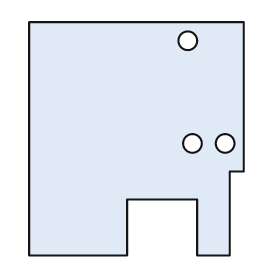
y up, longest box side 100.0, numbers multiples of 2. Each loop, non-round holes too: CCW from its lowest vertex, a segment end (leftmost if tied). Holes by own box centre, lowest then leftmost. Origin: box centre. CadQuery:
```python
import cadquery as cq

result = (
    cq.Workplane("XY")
    .moveTo(-46.0, -50.0)
    .lineTo(-4.0, -50.0)
    .lineTo(-4.0, -26.0)
    .lineTo(26.0, -26.0)
    .lineTo(26.0, -50.0)
    .lineTo(40.0, -50.0)
    .lineTo(40.0, -14.0)
    .lineTo(46.0, -14.0)
    .lineTo(46.0, 50.0)
    .lineTo(-46.0, 50.0)
    .close()
    .moveTo(24.0, -2.0)
    .circle(4.0)
    .moveTo(38.0, -2.0)
    .circle(4.0)
    .moveTo(22.0, 42.0)
    .circle(4.0)
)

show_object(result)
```